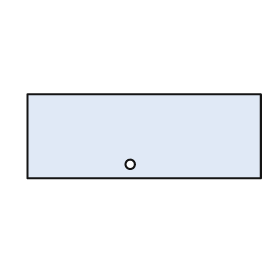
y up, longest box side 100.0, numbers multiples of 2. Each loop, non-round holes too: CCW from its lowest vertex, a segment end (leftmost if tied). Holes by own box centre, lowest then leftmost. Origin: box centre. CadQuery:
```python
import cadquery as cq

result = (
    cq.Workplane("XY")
    .moveTo(-50.0, -18.0)
    .lineTo(50.0, -18.0)
    .lineTo(50.0, 18.0)
    .lineTo(-50.0, 18.0)
    .close()
    .moveTo(-6.0, -12.0)
    .circle(2.0)
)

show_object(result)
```